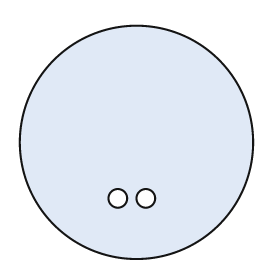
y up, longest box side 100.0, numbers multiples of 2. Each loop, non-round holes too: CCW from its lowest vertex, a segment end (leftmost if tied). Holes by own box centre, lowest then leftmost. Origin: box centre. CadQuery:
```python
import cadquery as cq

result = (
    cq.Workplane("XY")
    .moveTo(0.0, 0.0)
    .circle(50.0)
    .moveTo(-8.0, -24.0)
    .circle(4.0)
    .moveTo(4.0, -24.0)
    .circle(4.0)
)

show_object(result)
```